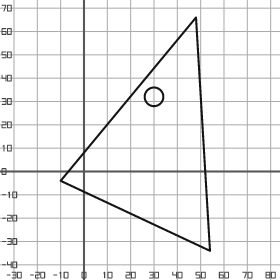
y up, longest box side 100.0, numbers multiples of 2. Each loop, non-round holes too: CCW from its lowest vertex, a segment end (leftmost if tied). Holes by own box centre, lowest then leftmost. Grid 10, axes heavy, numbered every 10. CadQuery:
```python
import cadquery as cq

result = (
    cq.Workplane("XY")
    .moveTo(54.0, -34.0)
    .lineTo(48.0, 66.0)
    .lineTo(-10.0, -4.0)
    .close()
    .moveTo(30.0, 32.0)
    .circle(4.0)
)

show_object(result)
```